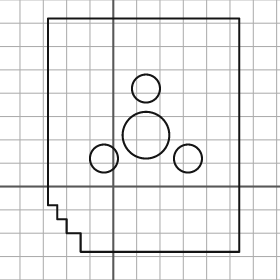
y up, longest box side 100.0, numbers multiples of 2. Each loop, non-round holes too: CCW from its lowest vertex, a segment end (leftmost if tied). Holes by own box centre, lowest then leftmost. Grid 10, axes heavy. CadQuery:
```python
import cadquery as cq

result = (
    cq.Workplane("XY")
    .moveTo(-14.0, -28.0)
    .lineTo(54.0, -28.0)
    .lineTo(54.0, 72.0)
    .lineTo(-28.0, 72.0)
    .lineTo(-28.0, -8.0)
    .lineTo(-24.0, -8.0)
    .lineTo(-24.0, -14.0)
    .lineTo(-20.0, -14.0)
    .lineTo(-20.0, -20.0)
    .lineTo(-14.0, -20.0)
    .close()
    .moveTo(-4.0, 12.0)
    .circle(6.0)
    .moveTo(32.0, 12.0)
    .circle(6.0)
    .moveTo(14.0, 22.0)
    .circle(10.0)
    .moveTo(14.0, 42.0)
    .circle(6.0)
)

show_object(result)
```